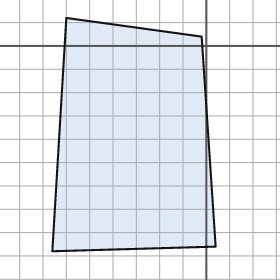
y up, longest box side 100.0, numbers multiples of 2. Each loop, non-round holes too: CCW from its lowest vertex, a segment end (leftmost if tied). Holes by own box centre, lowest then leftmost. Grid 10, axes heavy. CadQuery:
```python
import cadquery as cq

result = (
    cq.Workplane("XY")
    .moveTo(-66.0, -88.0)
    .lineTo(4.0, -86.0)
    .lineTo(-2.0, 4.0)
    .lineTo(-60.0, 12.0)
    .close()
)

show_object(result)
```